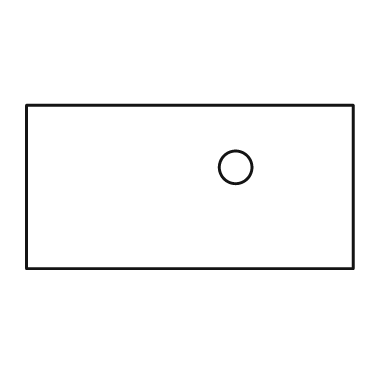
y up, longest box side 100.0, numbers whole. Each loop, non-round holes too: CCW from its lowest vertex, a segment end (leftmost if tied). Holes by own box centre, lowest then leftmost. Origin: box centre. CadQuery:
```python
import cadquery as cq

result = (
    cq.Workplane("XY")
    .moveTo(-50.0, -25.0)
    .lineTo(50.0, -25.0)
    .lineTo(50.0, 25.0)
    .lineTo(-50.0, 25.0)
    .close()
    .moveTo(14.0, 6.0)
    .circle(5.0)
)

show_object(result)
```